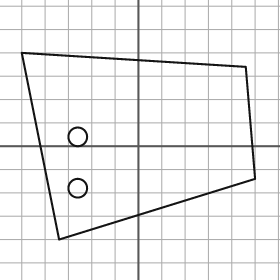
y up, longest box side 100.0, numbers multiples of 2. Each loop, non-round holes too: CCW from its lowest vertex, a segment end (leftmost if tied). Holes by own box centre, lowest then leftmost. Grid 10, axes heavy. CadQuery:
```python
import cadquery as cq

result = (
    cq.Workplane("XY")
    .moveTo(-34.0, -40.0)
    .lineTo(50.0, -14.0)
    .lineTo(46.0, 34.0)
    .lineTo(-50.0, 40.0)
    .close()
    .moveTo(-26.0, -18.0)
    .circle(4.0)
    .moveTo(-26.0, 4.0)
    .circle(4.0)
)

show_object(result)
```